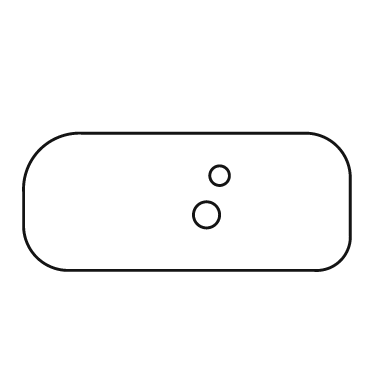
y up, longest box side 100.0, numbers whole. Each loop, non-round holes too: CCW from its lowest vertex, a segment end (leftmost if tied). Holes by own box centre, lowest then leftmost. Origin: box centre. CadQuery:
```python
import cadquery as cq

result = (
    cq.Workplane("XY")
    .moveTo(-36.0, -21.0)
    .lineTo(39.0, -21.0)
    .threePointArc((47.0, -18.0), (50.0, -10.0))
    .lineTo(50.0, 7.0)
    .threePointArc((46.0, 17.0), (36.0, 21.0))
    .lineTo(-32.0, 21.0)
    .threePointArc((-45.0, 16.0), (-50.0, 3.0))
    .lineTo(-50.0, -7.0)
    .threePointArc((-46.0, -17.0), (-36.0, -21.0))
    .close()
    .moveTo(6.0, -4.0)
    .circle(4.0)
    .moveTo(10.0, 8.0)
    .circle(3.0)
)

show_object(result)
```